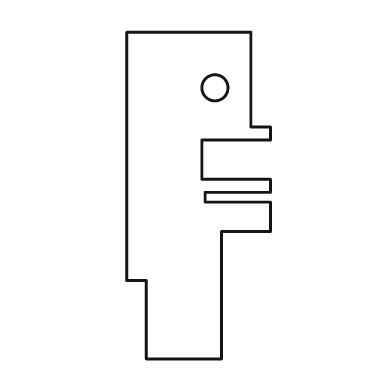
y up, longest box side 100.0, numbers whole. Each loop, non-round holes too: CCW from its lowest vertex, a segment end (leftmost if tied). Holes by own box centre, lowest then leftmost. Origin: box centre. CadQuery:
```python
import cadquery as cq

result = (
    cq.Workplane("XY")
    .moveTo(-16.0, -50.0)
    .lineTo(7.0, -50.0)
    .lineTo(7.0, -11.0)
    .lineTo(22.0, -11.0)
    .lineTo(22.0, -2.0)
    .lineTo(2.0, -2.0)
    .lineTo(2.0, 1.0)
    .lineTo(22.0, 1.0)
    .lineTo(22.0, 5.0)
    .lineTo(1.0, 5.0)
    .lineTo(1.0, 17.0)
    .lineTo(22.0, 17.0)
    .lineTo(22.0, 21.0)
    .lineTo(16.0, 21.0)
    .lineTo(16.0, 50.0)
    .lineTo(-22.0, 50.0)
    .lineTo(-22.0, -26.0)
    .lineTo(-16.0, -26.0)
    .close()
    .moveTo(5.0, 33.0)
    .circle(4.0)
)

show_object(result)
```